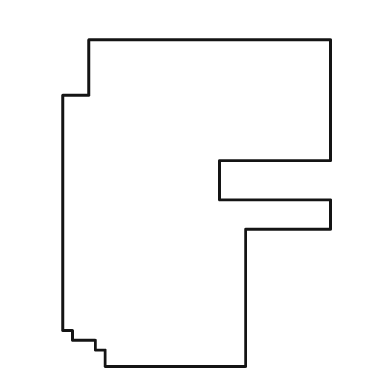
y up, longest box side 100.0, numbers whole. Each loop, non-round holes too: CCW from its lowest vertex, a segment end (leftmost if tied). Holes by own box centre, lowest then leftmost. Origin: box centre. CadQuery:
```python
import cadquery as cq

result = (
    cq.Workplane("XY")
    .moveTo(-28.0, -50.0)
    .lineTo(15.0, -50.0)
    .lineTo(15.0, -8.0)
    .lineTo(41.0, -8.0)
    .lineTo(41.0, 1.0)
    .lineTo(7.0, 1.0)
    .lineTo(7.0, 13.0)
    .lineTo(41.0, 13.0)
    .lineTo(41.0, 50.0)
    .lineTo(-33.0, 50.0)
    .lineTo(-33.0, 33.0)
    .lineTo(-41.0, 33.0)
    .lineTo(-41.0, -39.0)
    .lineTo(-38.0, -39.0)
    .lineTo(-38.0, -42.0)
    .lineTo(-31.0, -42.0)
    .lineTo(-31.0, -45.0)
    .lineTo(-28.0, -45.0)
    .close()
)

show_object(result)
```